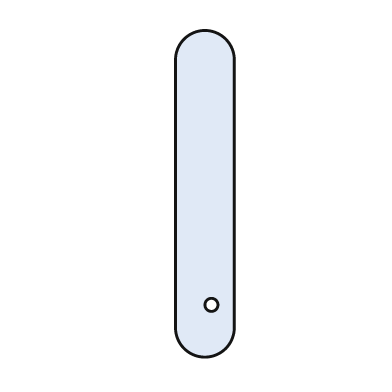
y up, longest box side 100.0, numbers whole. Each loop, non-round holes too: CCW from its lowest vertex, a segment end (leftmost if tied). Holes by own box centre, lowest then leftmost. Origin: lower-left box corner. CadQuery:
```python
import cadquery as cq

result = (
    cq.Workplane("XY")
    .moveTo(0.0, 9.0)
    .threePointArc((9.0, 0.0), (18.0, 9.0))
    .lineTo(18.0, 91.0)
    .threePointArc((9.0, 100.0), (0.0, 91.0))
    .close()
    .moveTo(11.0, 16.0)
    .circle(2.0)
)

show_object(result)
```